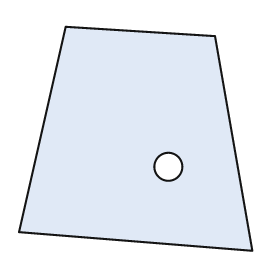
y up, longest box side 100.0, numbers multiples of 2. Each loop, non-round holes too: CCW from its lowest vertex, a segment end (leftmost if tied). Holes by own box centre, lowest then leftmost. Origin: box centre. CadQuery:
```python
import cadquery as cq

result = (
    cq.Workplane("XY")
    .moveTo(50.0, -48.0)
    .lineTo(34.0, 44.0)
    .lineTo(-30.0, 48.0)
    .lineTo(-50.0, -40.0)
    .close()
    .moveTo(14.0, -12.0)
    .circle(6.0)
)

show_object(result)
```